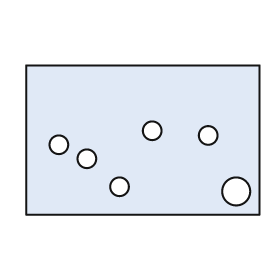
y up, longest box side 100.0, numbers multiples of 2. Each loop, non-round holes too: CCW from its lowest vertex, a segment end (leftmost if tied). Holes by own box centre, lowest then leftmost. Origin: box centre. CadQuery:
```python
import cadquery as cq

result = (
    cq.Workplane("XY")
    .moveTo(-50.0, -32.0)
    .lineTo(50.0, -32.0)
    .lineTo(50.0, 32.0)
    .lineTo(-50.0, 32.0)
    .close()
    .moveTo(40.0, -22.0)
    .circle(6.0)
    .moveTo(-10.0, -20.0)
    .circle(4.0)
    .moveTo(-24.0, -8.0)
    .circle(4.0)
    .moveTo(-36.0, -2.0)
    .circle(4.0)
    .moveTo(28.0, 2.0)
    .circle(4.0)
    .moveTo(4.0, 4.0)
    .circle(4.0)
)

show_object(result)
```